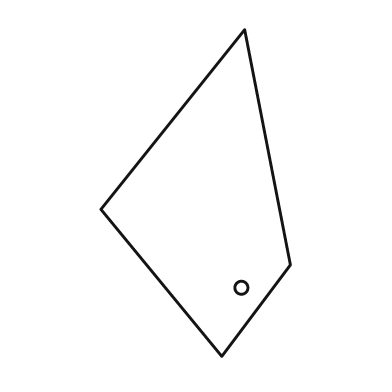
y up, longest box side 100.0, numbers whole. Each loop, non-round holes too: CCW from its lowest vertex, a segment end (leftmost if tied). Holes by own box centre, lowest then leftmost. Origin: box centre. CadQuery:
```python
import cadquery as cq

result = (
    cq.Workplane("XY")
    .moveTo(8.0, -50.0)
    .lineTo(29.0, -22.0)
    .lineTo(15.0, 50.0)
    .lineTo(-29.0, -5.0)
    .close()
    .moveTo(14.0, -29.0)
    .circle(2.0)
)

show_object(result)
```